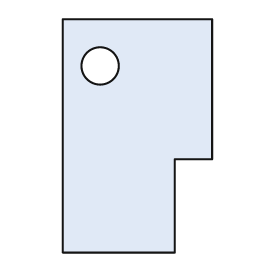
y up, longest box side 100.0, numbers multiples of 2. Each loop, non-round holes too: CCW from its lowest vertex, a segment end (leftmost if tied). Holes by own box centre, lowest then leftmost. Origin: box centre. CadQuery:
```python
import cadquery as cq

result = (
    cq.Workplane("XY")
    .moveTo(-32.0, -50.0)
    .lineTo(16.0, -50.0)
    .lineTo(16.0, -10.0)
    .lineTo(32.0, -10.0)
    .lineTo(32.0, 50.0)
    .lineTo(-32.0, 50.0)
    .close()
    .moveTo(-16.0, 30.0)
    .circle(8.0)
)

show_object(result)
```